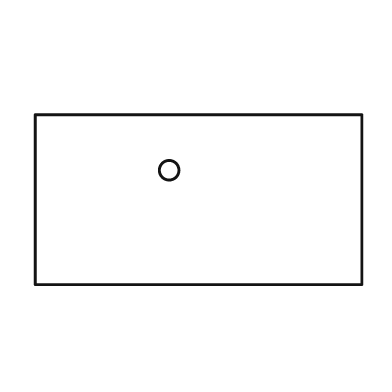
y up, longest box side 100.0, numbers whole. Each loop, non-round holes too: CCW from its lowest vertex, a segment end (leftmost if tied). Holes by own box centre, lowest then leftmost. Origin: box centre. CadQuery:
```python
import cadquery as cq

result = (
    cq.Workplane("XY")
    .moveTo(-50.0, -26.0)
    .lineTo(50.0, -26.0)
    .lineTo(50.0, 26.0)
    .lineTo(-50.0, 26.0)
    .close()
    .moveTo(-9.0, 9.0)
    .circle(3.0)
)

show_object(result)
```